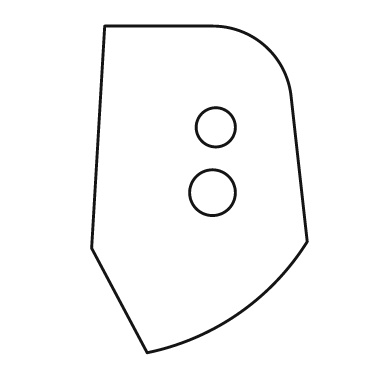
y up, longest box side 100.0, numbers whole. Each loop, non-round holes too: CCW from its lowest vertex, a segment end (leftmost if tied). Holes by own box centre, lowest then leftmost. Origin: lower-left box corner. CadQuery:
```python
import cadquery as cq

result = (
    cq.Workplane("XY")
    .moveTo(17.0, 0.0)
    .threePointArc((45.0, 12.0), (66.0, 34.0))
    .lineTo(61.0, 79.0)
    .threePointArc((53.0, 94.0), (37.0, 100.0))
    .lineTo(4.0, 100.0)
    .lineTo(0.0, 32.0)
    .close()
    .moveTo(37.0, 49.0)
    .circle(7.0)
    .moveTo(38.0, 69.0)
    .circle(6.0)
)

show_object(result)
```